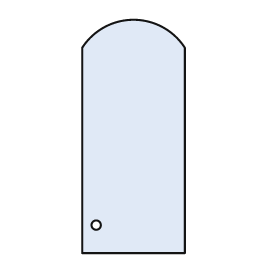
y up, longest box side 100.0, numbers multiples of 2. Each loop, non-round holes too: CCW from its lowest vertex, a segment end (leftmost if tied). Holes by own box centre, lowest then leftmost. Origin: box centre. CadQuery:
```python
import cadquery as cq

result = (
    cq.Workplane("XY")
    .moveTo(-22.0, -50.0)
    .lineTo(22.0, -50.0)
    .lineTo(22.0, 38.0)
    .threePointArc((0.0, 50.0), (-22.0, 38.0))
    .close()
    .moveTo(-16.0, -38.0)
    .circle(2.0)
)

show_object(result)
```